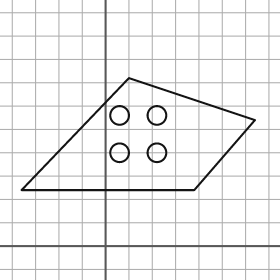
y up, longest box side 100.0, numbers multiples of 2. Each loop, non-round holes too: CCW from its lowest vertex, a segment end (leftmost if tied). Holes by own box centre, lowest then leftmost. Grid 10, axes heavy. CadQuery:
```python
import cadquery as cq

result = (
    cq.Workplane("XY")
    .moveTo(-36.0, 24.0)
    .lineTo(38.0, 24.0)
    .lineTo(64.0, 54.0)
    .lineTo(10.0, 72.0)
    .close()
    .moveTo(6.0, 40.0)
    .circle(4.0)
    .moveTo(22.0, 40.0)
    .circle(4.0)
    .moveTo(6.0, 56.0)
    .circle(4.0)
    .moveTo(22.0, 56.0)
    .circle(4.0)
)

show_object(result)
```